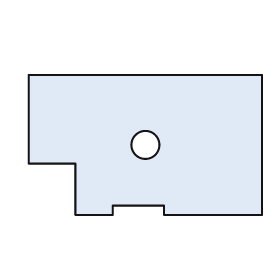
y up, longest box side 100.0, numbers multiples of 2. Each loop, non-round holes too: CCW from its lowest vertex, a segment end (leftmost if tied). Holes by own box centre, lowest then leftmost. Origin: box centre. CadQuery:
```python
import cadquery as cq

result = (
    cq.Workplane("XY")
    .moveTo(-30.0, -30.0)
    .lineTo(-14.0, -30.0)
    .lineTo(-14.0, -26.0)
    .lineTo(8.0, -26.0)
    .lineTo(8.0, -30.0)
    .lineTo(50.0, -30.0)
    .lineTo(50.0, 30.0)
    .lineTo(-50.0, 30.0)
    .lineTo(-50.0, -8.0)
    .lineTo(-30.0, -8.0)
    .close()
    .moveTo(0.0, 0.0)
    .circle(6.0)
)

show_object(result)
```